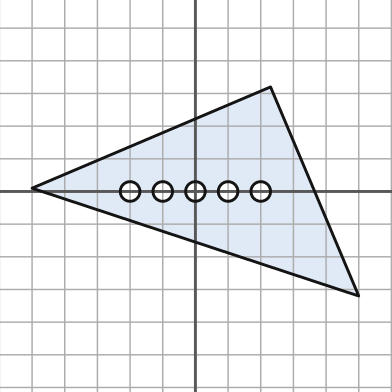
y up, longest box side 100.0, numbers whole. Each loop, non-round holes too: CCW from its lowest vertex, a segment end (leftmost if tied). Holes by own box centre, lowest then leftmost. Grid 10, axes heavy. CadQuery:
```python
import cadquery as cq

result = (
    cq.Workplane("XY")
    .moveTo(50.0, -32.0)
    .lineTo(23.0, 32.0)
    .lineTo(-50.0, 1.0)
    .close()
    .moveTo(-20.0, 0.0)
    .circle(3.0)
    .moveTo(-10.0, 0.0)
    .circle(3.0)
    .moveTo(0.0, 0.0)
    .circle(3.0)
    .moveTo(10.0, 0.0)
    .circle(3.0)
    .moveTo(20.0, 0.0)
    .circle(3.0)
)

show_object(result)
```